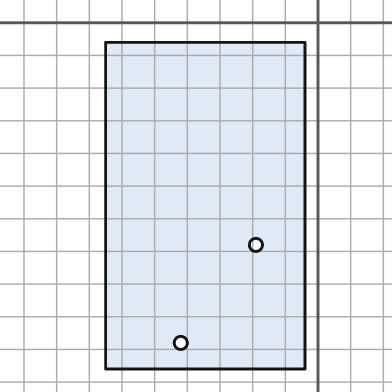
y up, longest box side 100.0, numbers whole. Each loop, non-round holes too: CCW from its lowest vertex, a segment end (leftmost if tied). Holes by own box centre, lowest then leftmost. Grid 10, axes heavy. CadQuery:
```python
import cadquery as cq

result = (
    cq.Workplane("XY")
    .moveTo(-65.0, -106.0)
    .lineTo(-4.0, -106.0)
    .lineTo(-4.0, -6.0)
    .lineTo(-65.0, -6.0)
    .close()
    .moveTo(-42.0, -98.0)
    .circle(2.0)
    .moveTo(-19.0, -68.0)
    .circle(2.0)
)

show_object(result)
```